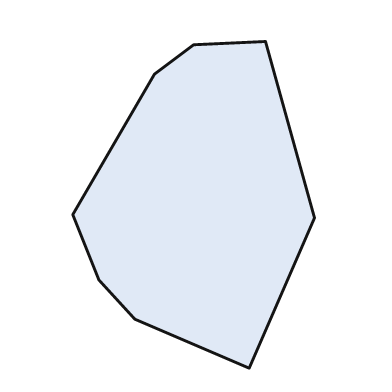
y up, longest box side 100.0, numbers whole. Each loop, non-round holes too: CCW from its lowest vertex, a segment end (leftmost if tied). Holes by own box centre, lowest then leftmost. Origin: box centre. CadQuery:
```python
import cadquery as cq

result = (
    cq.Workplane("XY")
    .moveTo(17.0, -50.0)
    .lineTo(37.0, -4.0)
    .lineTo(22.0, 50.0)
    .lineTo(0.0, 49.0)
    .lineTo(-12.0, 40.0)
    .lineTo(-37.0, -3.0)
    .lineTo(-29.0, -23.0)
    .lineTo(-18.0, -35.0)
    .close()
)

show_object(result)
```